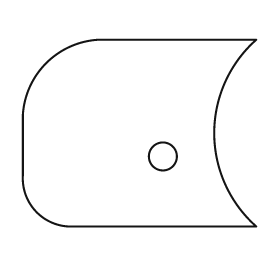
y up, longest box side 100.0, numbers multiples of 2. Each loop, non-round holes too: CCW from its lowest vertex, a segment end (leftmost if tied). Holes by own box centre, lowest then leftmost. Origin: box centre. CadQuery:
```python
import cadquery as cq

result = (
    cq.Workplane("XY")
    .moveTo(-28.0, -40.0)
    .lineTo(50.0, -40.0)
    .threePointArc((32.0, 0.0), (50.0, 40.0))
    .lineTo(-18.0, 40.0)
    .threePointArc((-40.0, 30.0), (-50.0, 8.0))
    .lineTo(-50.0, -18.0)
    .threePointArc((-44.0, -34.0), (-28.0, -40.0))
    .close()
    .moveTo(10.0, -10.0)
    .circle(6.0)
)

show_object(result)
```